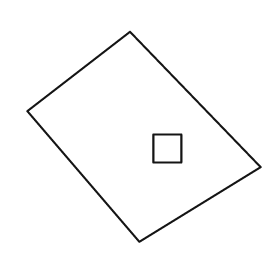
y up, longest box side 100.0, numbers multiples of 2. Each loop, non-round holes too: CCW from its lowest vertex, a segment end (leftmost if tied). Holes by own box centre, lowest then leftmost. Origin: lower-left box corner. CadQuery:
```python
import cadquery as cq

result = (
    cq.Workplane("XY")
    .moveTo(48.0, 0.0)
    .lineTo(100.0, 32.0)
    .lineTo(44.0, 90.0)
    .lineTo(0.0, 56.0)
    .close()
    .moveTo(54.0, 34.0)
    .lineTo(66.0, 34.0)
    .lineTo(66.0, 46.0)
    .lineTo(54.0, 46.0)
    .close()
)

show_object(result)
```